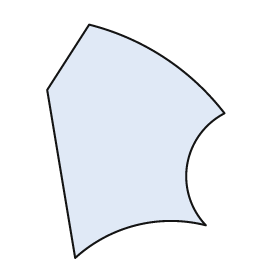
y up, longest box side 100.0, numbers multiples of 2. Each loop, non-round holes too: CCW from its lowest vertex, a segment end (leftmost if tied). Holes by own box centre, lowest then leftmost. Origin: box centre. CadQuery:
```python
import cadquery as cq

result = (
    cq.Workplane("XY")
    .moveTo(-26.0, -50.0)
    .threePointArc((0.0, -36.0), (30.0, -36.0))
    .threePointArc((22.0, -10.0), (38.0, 12.0))
    .threePointArc((12.0, 36.0), (-20.0, 50.0))
    .lineTo(-38.0, 22.0)
    .close()
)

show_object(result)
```